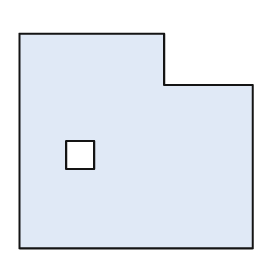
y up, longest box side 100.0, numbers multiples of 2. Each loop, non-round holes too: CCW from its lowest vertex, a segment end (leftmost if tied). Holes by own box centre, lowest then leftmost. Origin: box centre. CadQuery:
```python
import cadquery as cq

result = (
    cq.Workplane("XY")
    .moveTo(-50.0, -46.0)
    .lineTo(50.0, -46.0)
    .lineTo(50.0, 24.0)
    .lineTo(12.0, 24.0)
    .lineTo(12.0, 46.0)
    .lineTo(-50.0, 46.0)
    .close()
    .moveTo(-30.0, -12.0)
    .lineTo(-18.0, -12.0)
    .lineTo(-18.0, 0.0)
    .lineTo(-30.0, 0.0)
    .close()
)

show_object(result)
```